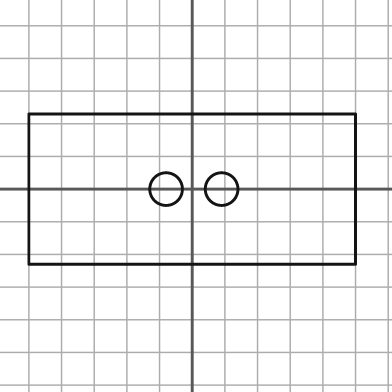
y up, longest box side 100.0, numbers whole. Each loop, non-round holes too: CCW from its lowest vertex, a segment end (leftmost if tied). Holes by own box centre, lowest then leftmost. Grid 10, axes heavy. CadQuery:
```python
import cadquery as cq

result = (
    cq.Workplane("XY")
    .moveTo(-50.0, -23.0)
    .lineTo(50.0, -23.0)
    .lineTo(50.0, 23.0)
    .lineTo(-50.0, 23.0)
    .close()
    .moveTo(-8.0, 0.0)
    .circle(5.0)
    .moveTo(9.0, 0.0)
    .circle(5.0)
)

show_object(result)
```